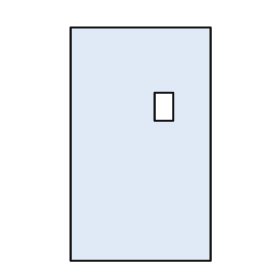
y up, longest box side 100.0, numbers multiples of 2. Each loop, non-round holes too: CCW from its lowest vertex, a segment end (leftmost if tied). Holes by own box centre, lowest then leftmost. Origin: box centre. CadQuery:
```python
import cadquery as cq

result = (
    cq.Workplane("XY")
    .moveTo(-30.0, -50.0)
    .lineTo(30.0, -50.0)
    .lineTo(30.0, 50.0)
    .lineTo(-30.0, 50.0)
    .close()
    .moveTo(6.0, 10.0)
    .lineTo(14.0, 10.0)
    .lineTo(14.0, 22.0)
    .lineTo(6.0, 22.0)
    .close()
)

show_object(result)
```